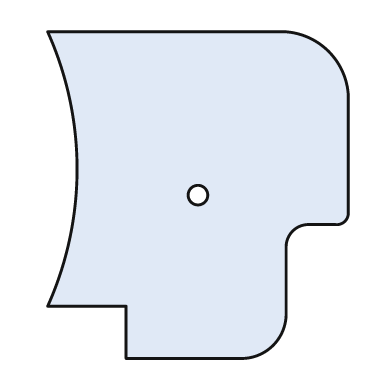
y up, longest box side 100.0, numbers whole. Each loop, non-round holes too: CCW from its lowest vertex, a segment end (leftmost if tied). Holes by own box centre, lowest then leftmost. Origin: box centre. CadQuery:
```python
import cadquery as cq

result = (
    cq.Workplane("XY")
    .moveTo(-22.0, -50.0)
    .lineTo(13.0, -50.0)
    .threePointArc((23.0, -46.0), (27.0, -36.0))
    .lineTo(27.0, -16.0)
    .threePointArc((29.0, -11.0), (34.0, -9.0))
    .lineTo(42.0, -9.0)
    .threePointArc((45.0, -8.0), (46.0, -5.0))
    .lineTo(46.0, 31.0)
    .threePointArc((40.0, 44.0), (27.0, 50.0))
    .lineTo(-46.0, 50.0)
    .threePointArc((-37.0, 8.0), (-46.0, -34.0))
    .lineTo(-22.0, -34.0)
    .close()
    .moveTo(0.0, 0.0)
    .circle(3.0)
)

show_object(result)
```